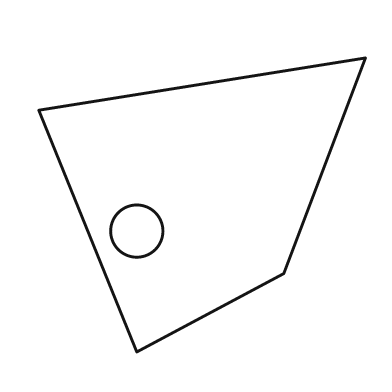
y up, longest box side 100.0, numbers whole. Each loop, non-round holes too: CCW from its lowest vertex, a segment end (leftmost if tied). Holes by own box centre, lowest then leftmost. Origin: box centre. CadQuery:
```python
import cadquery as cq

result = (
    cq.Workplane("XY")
    .moveTo(-20.0, -45.0)
    .lineTo(25.0, -21.0)
    .lineTo(50.0, 45.0)
    .lineTo(-50.0, 29.0)
    .close()
    .moveTo(-20.0, -8.0)
    .circle(8.0)
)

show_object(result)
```